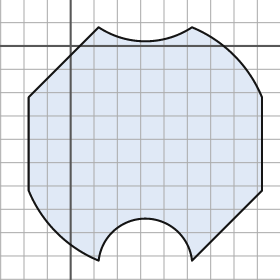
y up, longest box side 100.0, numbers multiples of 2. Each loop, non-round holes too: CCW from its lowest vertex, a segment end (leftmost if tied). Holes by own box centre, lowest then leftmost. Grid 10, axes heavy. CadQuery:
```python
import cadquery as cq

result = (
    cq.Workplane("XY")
    .moveTo(12.0, -92.0)
    .threePointArc((32.0, -74.0), (52.0, -92.0))
    .lineTo(82.0, -62.0)
    .lineTo(82.0, -22.0)
    .threePointArc((70.0, -4.0), (52.0, 8.0))
    .threePointArc((32.0, 2.0), (12.0, 8.0))
    .lineTo(-18.0, -22.0)
    .lineTo(-18.0, -62.0)
    .threePointArc((-6.0, -80.0), (12.0, -92.0))
    .close()
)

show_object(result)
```